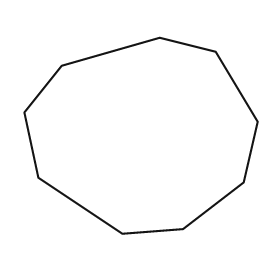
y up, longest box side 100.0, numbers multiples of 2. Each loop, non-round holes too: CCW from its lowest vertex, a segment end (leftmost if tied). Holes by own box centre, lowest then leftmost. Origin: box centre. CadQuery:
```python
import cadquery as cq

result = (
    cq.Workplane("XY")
    .moveTo(-8.0, -42.0)
    .lineTo(18.0, -40.0)
    .lineTo(44.0, -20.0)
    .lineTo(50.0, 6.0)
    .lineTo(32.0, 36.0)
    .lineTo(8.0, 42.0)
    .lineTo(-34.0, 30.0)
    .lineTo(-50.0, 10.0)
    .lineTo(-44.0, -18.0)
    .close()
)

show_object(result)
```